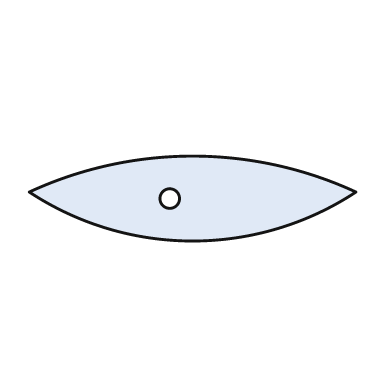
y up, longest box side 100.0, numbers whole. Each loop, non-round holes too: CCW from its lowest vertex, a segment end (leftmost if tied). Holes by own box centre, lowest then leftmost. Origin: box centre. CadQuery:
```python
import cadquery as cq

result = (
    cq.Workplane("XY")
    .moveTo(-50.0, 2.0)
    .threePointArc((0.0, -13.0), (50.0, 2.0))
    .threePointArc((0.0, 13.0), (-50.0, 2.0))
    .close()
    .moveTo(-7.0, 0.0)
    .circle(3.0)
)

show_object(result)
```